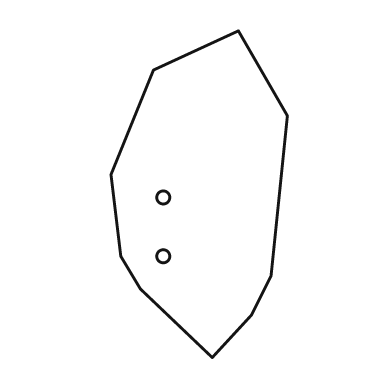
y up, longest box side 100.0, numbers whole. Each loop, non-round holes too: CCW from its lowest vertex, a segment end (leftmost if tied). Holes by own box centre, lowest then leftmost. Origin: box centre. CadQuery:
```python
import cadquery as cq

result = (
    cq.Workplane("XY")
    .moveTo(4.0, -50.0)
    .lineTo(16.0, -37.0)
    .lineTo(22.0, -25.0)
    .lineTo(27.0, 24.0)
    .lineTo(12.0, 50.0)
    .lineTo(-14.0, 38.0)
    .lineTo(-27.0, 6.0)
    .lineTo(-24.0, -19.0)
    .lineTo(-18.0, -29.0)
    .close()
    .moveTo(-11.0, -19.0)
    .circle(2.0)
    .moveTo(-11.0, -1.0)
    .circle(2.0)
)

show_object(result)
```